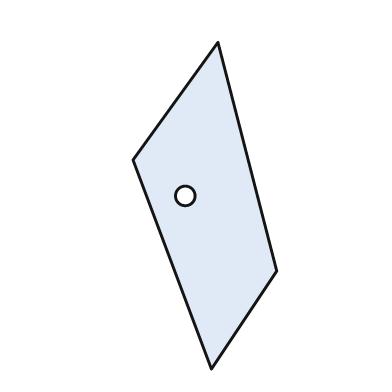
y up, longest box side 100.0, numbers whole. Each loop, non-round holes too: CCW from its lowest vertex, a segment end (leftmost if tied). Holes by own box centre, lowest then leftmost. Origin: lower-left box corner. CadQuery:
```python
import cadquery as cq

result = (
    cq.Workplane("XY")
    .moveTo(24.0, 0.0)
    .lineTo(44.0, 30.0)
    .lineTo(26.0, 100.0)
    .lineTo(0.0, 64.0)
    .close()
    .moveTo(16.0, 53.0)
    .circle(3.0)
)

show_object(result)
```